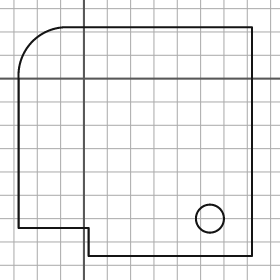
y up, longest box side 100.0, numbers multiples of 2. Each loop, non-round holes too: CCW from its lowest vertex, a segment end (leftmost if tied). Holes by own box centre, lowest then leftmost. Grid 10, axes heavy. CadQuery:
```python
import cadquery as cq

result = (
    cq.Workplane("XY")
    .moveTo(2.0, -76.0)
    .lineTo(72.0, -76.0)
    .lineTo(72.0, 22.0)
    .lineTo(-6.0, 22.0)
    .threePointArc((-22.0, 16.0), (-28.0, 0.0))
    .lineTo(-28.0, -64.0)
    .lineTo(2.0, -64.0)
    .close()
    .moveTo(54.0, -60.0)
    .circle(6.0)
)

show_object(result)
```